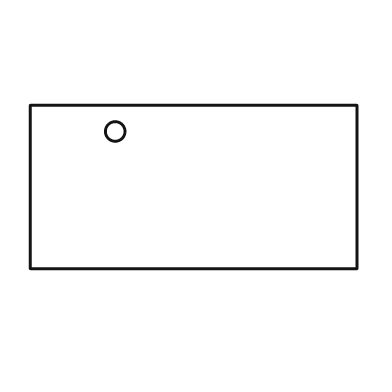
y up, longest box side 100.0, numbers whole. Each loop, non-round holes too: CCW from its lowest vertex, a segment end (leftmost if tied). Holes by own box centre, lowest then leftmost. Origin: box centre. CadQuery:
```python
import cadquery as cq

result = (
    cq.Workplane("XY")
    .moveTo(-50.0, -25.0)
    .lineTo(50.0, -25.0)
    .lineTo(50.0, 25.0)
    .lineTo(-50.0, 25.0)
    .close()
    .moveTo(-24.0, 17.0)
    .circle(3.0)
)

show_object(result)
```